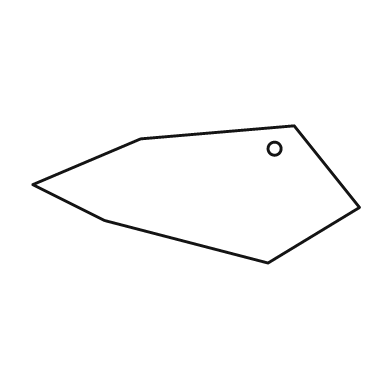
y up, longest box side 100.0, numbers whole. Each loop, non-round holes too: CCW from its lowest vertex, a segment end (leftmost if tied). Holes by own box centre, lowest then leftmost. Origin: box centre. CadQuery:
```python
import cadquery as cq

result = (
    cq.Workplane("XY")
    .moveTo(22.0, -21.0)
    .lineTo(50.0, -4.0)
    .lineTo(30.0, 21.0)
    .lineTo(-17.0, 17.0)
    .lineTo(-50.0, 3.0)
    .lineTo(-28.0, -8.0)
    .close()
    .moveTo(24.0, 14.0)
    .circle(2.0)
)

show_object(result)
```